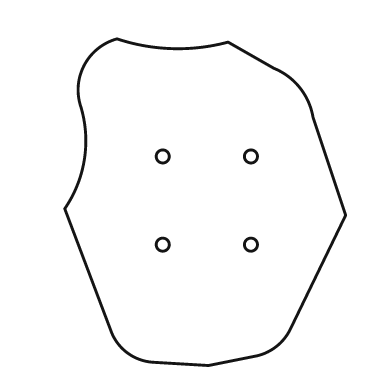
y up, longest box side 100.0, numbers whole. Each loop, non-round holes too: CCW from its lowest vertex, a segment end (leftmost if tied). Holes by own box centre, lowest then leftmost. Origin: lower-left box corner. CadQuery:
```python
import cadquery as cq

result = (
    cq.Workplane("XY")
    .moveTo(44.0, 0.0)
    .lineTo(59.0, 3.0)
    .threePointArc((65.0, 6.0), (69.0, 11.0))
    .lineTo(86.0, 46.0)
    .lineTo(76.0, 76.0)
    .threePointArc((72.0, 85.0), (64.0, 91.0))
    .lineTo(50.0, 99.0)
    .threePointArc((33.0, 97.0), (16.0, 100.0))
    .threePointArc((6.0, 92.0), (5.0, 79.0))
    .threePointArc((6.0, 63.0), (0.0, 48.0))
    .lineTo(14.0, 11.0)
    .threePointArc((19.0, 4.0), (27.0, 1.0))
    .close()
    .moveTo(30.0, 37.0)
    .circle(2.0)
    .moveTo(57.0, 37.0)
    .circle(2.0)
    .moveTo(30.0, 64.0)
    .circle(2.0)
    .moveTo(57.0, 64.0)
    .circle(2.0)
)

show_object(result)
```